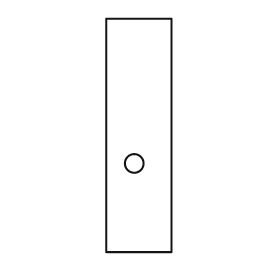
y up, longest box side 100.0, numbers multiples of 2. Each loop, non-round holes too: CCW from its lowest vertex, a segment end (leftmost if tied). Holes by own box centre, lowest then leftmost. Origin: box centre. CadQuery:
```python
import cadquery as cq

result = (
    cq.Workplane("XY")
    .moveTo(-14.0, -50.0)
    .lineTo(14.0, -50.0)
    .lineTo(14.0, 50.0)
    .lineTo(-14.0, 50.0)
    .close()
    .moveTo(-2.0, -12.0)
    .circle(4.0)
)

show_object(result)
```